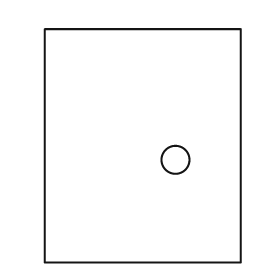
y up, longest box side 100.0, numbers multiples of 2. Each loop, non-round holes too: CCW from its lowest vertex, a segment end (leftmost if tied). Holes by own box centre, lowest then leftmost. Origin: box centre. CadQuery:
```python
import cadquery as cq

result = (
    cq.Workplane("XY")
    .moveTo(-42.0, -50.0)
    .lineTo(42.0, -50.0)
    .lineTo(42.0, 50.0)
    .lineTo(-42.0, 50.0)
    .close()
    .moveTo(14.0, -6.0)
    .circle(6.0)
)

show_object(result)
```